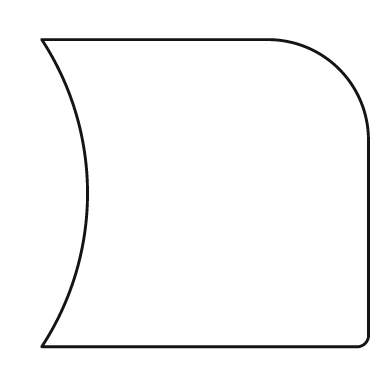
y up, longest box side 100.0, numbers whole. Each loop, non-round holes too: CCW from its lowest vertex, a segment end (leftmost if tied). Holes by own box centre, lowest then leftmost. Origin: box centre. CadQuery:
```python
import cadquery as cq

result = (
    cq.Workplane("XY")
    .moveTo(-50.0, -47.0)
    .lineTo(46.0, -47.0)
    .threePointArc((49.0, -46.0), (50.0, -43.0))
    .lineTo(50.0, 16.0)
    .threePointArc((41.0, 38.0), (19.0, 47.0))
    .lineTo(-50.0, 47.0)
    .threePointArc((-36.0, 0.0), (-50.0, -47.0))
    .close()
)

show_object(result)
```